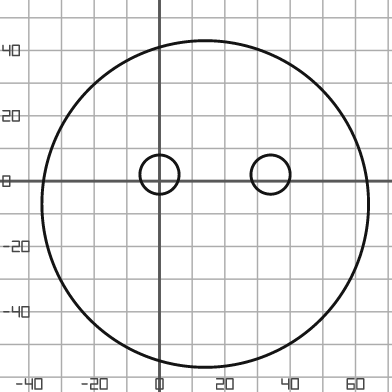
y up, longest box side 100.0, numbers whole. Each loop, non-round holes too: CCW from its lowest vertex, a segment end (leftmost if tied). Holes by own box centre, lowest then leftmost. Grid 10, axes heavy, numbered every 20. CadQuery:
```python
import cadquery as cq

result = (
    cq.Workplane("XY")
    .moveTo(14.0, -7.0)
    .circle(50.0)
    .moveTo(0.0, 2.0)
    .circle(6.0)
    .moveTo(34.0, 2.0)
    .circle(6.0)
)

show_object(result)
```